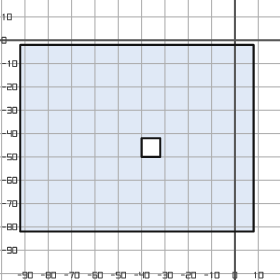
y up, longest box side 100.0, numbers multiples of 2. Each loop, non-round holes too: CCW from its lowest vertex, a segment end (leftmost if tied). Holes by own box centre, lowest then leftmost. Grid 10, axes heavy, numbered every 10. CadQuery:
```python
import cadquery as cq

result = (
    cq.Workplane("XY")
    .moveTo(-92.0, -82.0)
    .lineTo(8.0, -82.0)
    .lineTo(8.0, -2.0)
    .lineTo(-92.0, -2.0)
    .close()
    .moveTo(-40.0, -50.0)
    .lineTo(-32.0, -50.0)
    .lineTo(-32.0, -42.0)
    .lineTo(-40.0, -42.0)
    .close()
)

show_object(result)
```